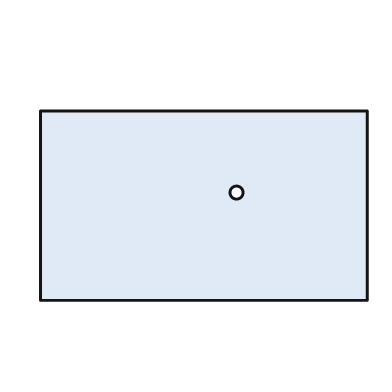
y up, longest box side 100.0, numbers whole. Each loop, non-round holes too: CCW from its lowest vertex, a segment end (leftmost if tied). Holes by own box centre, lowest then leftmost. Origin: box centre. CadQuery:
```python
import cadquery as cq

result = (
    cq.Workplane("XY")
    .moveTo(-50.0, -29.0)
    .lineTo(50.0, -29.0)
    .lineTo(50.0, 29.0)
    .lineTo(-50.0, 29.0)
    .close()
    .moveTo(10.0, 4.0)
    .circle(2.0)
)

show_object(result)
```